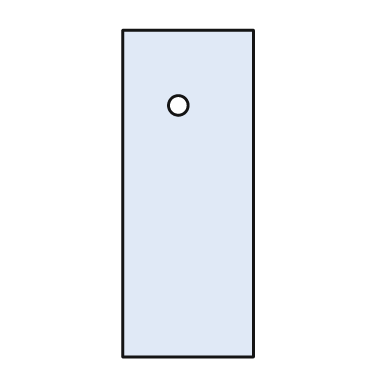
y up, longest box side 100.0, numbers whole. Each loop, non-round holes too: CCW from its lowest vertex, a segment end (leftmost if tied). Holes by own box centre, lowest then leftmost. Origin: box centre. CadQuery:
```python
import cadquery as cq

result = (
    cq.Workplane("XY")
    .moveTo(-20.0, -50.0)
    .lineTo(20.0, -50.0)
    .lineTo(20.0, 50.0)
    .lineTo(-20.0, 50.0)
    .close()
    .moveTo(-3.0, 27.0)
    .circle(3.0)
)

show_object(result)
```